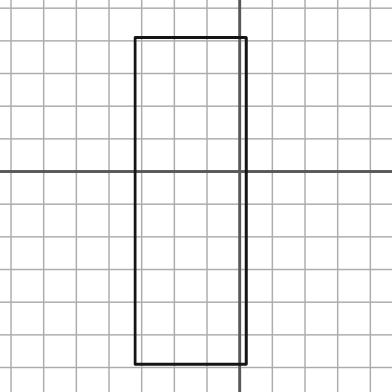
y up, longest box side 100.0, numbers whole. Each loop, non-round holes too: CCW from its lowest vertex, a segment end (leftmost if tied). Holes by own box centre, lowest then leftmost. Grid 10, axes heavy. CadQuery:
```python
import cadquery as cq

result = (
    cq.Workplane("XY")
    .moveTo(-32.0, -59.0)
    .lineTo(2.0, -59.0)
    .lineTo(2.0, 41.0)
    .lineTo(-32.0, 41.0)
    .close()
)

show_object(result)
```